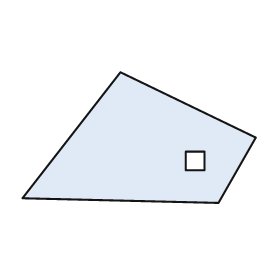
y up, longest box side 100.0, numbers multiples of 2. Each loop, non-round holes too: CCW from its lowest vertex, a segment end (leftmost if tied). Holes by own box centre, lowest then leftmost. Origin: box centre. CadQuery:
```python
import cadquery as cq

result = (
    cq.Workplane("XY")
    .moveTo(34.0, -28.0)
    .lineTo(50.0, 0.0)
    .lineTo(-8.0, 28.0)
    .lineTo(-50.0, -26.0)
    .close()
    .moveTo(20.0, -14.0)
    .lineTo(28.0, -14.0)
    .lineTo(28.0, -6.0)
    .lineTo(20.0, -6.0)
    .close()
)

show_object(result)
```